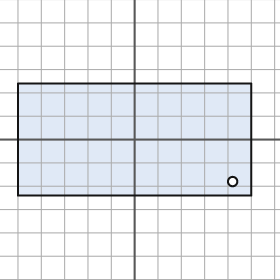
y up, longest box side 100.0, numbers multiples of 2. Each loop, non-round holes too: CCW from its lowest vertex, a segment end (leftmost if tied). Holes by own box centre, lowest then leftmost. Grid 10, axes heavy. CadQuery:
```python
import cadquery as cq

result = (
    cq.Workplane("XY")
    .moveTo(-50.0, -24.0)
    .lineTo(50.0, -24.0)
    .lineTo(50.0, 24.0)
    .lineTo(-50.0, 24.0)
    .close()
    .moveTo(42.0, -18.0)
    .circle(2.0)
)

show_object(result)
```